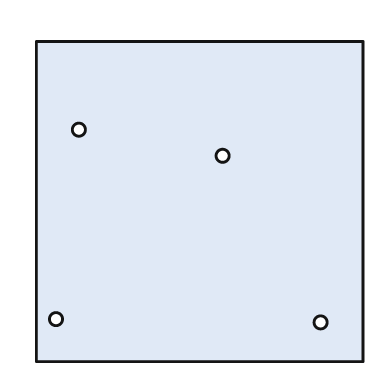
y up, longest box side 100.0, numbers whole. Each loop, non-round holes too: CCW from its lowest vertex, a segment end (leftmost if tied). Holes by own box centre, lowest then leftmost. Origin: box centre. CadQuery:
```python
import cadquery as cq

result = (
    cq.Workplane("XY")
    .moveTo(-50.0, -49.0)
    .lineTo(50.0, -49.0)
    .lineTo(50.0, 49.0)
    .lineTo(-50.0, 49.0)
    .close()
    .moveTo(37.0, -37.0)
    .circle(2.0)
    .moveTo(-44.0, -36.0)
    .circle(2.0)
    .moveTo(7.0, 14.0)
    .circle(2.0)
    .moveTo(-37.0, 22.0)
    .circle(2.0)
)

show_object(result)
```